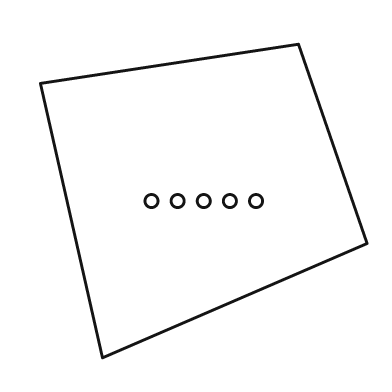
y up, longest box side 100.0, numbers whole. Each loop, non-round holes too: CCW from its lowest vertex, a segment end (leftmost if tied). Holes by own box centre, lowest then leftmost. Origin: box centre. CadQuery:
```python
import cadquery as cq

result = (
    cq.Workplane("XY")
    .moveTo(-31.0, -48.0)
    .lineTo(50.0, -13.0)
    .lineTo(29.0, 48.0)
    .lineTo(-50.0, 36.0)
    .close()
    .moveTo(-16.0, 0.0)
    .circle(2.0)
    .moveTo(-8.0, 0.0)
    .circle(2.0)
    .moveTo(0.0, 0.0)
    .circle(2.0)
    .moveTo(8.0, 0.0)
    .circle(2.0)
    .moveTo(16.0, 0.0)
    .circle(2.0)
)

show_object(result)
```